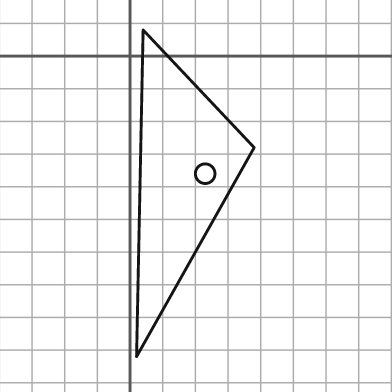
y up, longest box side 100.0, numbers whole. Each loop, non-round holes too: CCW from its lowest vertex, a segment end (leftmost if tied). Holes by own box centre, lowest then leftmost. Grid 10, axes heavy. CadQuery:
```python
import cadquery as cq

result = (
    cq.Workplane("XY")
    .moveTo(2.0, -92.0)
    .lineTo(38.0, -28.0)
    .lineTo(4.0, 8.0)
    .close()
    .moveTo(23.0, -36.0)
    .circle(3.0)
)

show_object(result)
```